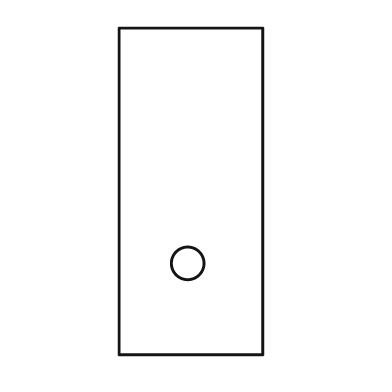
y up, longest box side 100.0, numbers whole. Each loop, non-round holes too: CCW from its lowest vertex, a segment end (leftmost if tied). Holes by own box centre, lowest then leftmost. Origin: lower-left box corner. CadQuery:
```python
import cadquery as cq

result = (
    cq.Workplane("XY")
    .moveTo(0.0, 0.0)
    .lineTo(44.0, 0.0)
    .lineTo(44.0, 100.0)
    .lineTo(0.0, 100.0)
    .close()
    .moveTo(21.0, 28.0)
    .circle(5.0)
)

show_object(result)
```